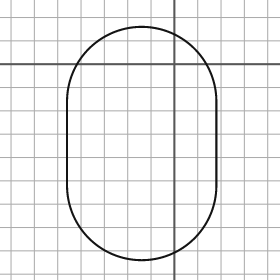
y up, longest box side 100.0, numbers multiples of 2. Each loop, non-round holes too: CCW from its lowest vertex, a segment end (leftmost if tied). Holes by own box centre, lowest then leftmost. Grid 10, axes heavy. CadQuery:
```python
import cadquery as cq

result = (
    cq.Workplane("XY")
    .moveTo(-46.0, -52.0)
    .threePointArc((-14.0, -84.0), (18.0, -52.0))
    .lineTo(18.0, -16.0)
    .threePointArc((-14.0, 16.0), (-46.0, -16.0))
    .close()
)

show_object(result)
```